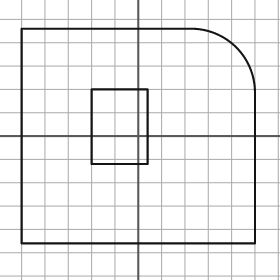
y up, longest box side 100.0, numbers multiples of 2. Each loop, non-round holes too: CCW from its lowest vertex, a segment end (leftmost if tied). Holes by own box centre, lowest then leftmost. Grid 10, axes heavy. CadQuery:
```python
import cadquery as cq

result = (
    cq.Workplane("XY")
    .moveTo(-50.0, -46.0)
    .lineTo(50.0, -46.0)
    .lineTo(50.0, 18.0)
    .threePointArc((42.0, 38.0), (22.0, 46.0))
    .lineTo(-50.0, 46.0)
    .close()
    .moveTo(-20.0, -12.0)
    .lineTo(4.0, -12.0)
    .lineTo(4.0, 20.0)
    .lineTo(-20.0, 20.0)
    .close()
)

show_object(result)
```